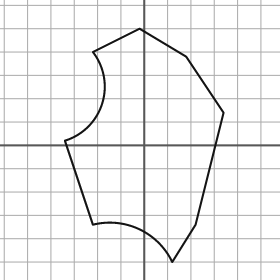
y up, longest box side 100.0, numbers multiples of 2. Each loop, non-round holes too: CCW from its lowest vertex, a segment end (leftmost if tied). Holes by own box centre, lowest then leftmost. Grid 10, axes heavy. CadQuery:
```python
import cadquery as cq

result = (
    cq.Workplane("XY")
    .moveTo(12.0, -50.0)
    .lineTo(22.0, -34.0)
    .lineTo(34.0, 14.0)
    .lineTo(18.0, 38.0)
    .lineTo(-2.0, 50.0)
    .lineTo(-22.0, 40.0)
    .threePointArc((-18.0, 18.0), (-34.0, 2.0))
    .lineTo(-22.0, -34.0)
    .threePointArc((-2.0, -36.0), (12.0, -50.0))
    .close()
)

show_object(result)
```